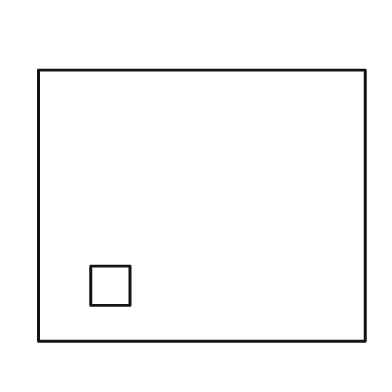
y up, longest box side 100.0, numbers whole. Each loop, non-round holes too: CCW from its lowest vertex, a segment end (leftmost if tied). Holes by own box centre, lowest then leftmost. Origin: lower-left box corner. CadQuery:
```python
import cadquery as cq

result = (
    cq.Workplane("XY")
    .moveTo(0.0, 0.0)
    .lineTo(100.0, 0.0)
    .lineTo(100.0, 83.0)
    .lineTo(0.0, 83.0)
    .close()
    .moveTo(16.0, 11.0)
    .lineTo(28.0, 11.0)
    .lineTo(28.0, 23.0)
    .lineTo(16.0, 23.0)
    .close()
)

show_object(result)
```